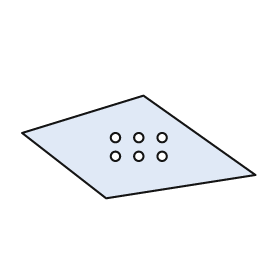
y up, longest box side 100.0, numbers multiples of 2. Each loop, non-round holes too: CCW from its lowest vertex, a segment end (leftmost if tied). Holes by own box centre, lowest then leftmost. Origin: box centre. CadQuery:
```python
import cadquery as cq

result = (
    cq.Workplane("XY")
    .moveTo(-14.0, -22.0)
    .lineTo(50.0, -12.0)
    .lineTo(2.0, 22.0)
    .lineTo(-50.0, 6.0)
    .close()
    .moveTo(-10.0, -4.0)
    .circle(2.0)
    .moveTo(0.0, -4.0)
    .circle(2.0)
    .moveTo(10.0, -4.0)
    .circle(2.0)
    .moveTo(-10.0, 4.0)
    .circle(2.0)
    .moveTo(0.0, 4.0)
    .circle(2.0)
    .moveTo(10.0, 4.0)
    .circle(2.0)
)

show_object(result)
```